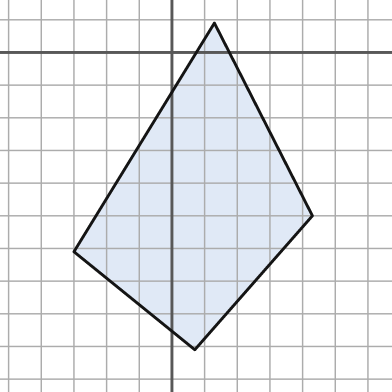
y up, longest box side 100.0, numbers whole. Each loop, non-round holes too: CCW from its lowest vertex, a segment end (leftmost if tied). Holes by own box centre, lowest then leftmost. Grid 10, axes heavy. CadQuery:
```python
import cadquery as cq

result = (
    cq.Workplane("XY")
    .moveTo(7.0, -91.0)
    .lineTo(43.0, -50.0)
    .lineTo(13.0, 9.0)
    .lineTo(-30.0, -61.0)
    .close()
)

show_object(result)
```